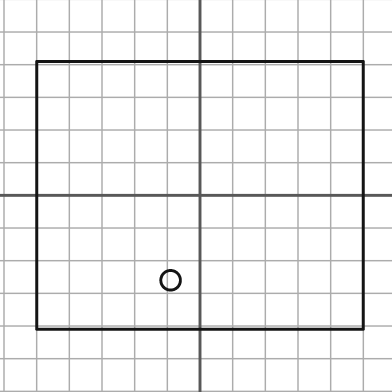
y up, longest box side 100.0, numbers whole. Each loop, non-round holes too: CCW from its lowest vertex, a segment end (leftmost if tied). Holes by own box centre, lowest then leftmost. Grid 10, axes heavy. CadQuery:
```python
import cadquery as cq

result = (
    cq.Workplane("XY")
    .moveTo(-50.0, -41.0)
    .lineTo(50.0, -41.0)
    .lineTo(50.0, 41.0)
    .lineTo(-50.0, 41.0)
    .close()
    .moveTo(-9.0, -26.0)
    .circle(3.0)
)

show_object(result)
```